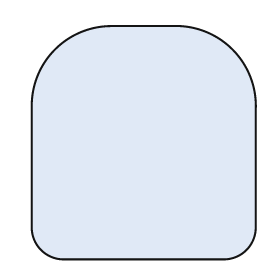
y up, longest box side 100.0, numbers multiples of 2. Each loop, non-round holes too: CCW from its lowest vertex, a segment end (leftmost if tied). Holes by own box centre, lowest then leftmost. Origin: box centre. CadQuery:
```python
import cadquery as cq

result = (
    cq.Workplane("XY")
    .moveTo(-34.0, -50.0)
    .lineTo(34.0, -50.0)
    .threePointArc((44.0, -46.0), (48.0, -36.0))
    .lineTo(48.0, 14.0)
    .threePointArc((38.0, 40.0), (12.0, 50.0))
    .lineTo(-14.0, 50.0)
    .threePointArc((-38.0, 40.0), (-48.0, 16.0))
    .lineTo(-48.0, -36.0)
    .threePointArc((-44.0, -46.0), (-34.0, -50.0))
    .close()
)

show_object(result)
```